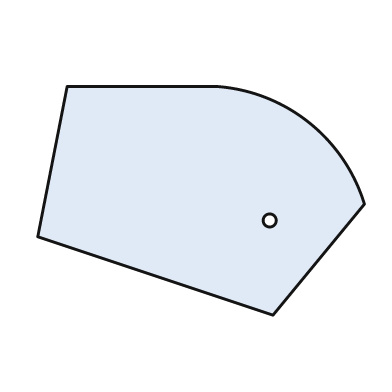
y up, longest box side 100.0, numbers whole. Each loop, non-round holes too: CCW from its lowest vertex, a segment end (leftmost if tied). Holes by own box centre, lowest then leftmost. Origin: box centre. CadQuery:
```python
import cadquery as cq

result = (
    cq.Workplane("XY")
    .moveTo(22.0, -35.0)
    .lineTo(50.0, -1.0)
    .threePointArc((33.0, 24.0), (5.0, 35.0))
    .lineTo(-41.0, 35.0)
    .lineTo(-50.0, -11.0)
    .close()
    .moveTo(21.0, -6.0)
    .circle(2.0)
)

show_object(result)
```